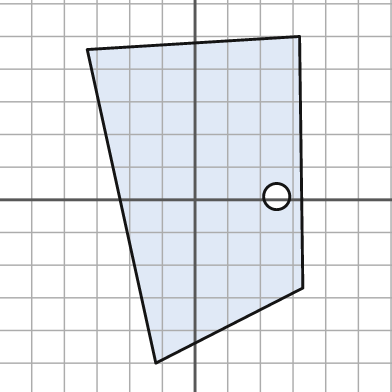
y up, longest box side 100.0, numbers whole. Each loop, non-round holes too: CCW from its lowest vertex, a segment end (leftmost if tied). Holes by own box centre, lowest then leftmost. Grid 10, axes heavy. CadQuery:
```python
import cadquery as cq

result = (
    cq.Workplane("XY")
    .moveTo(-12.0, -50.0)
    .lineTo(33.0, -27.0)
    .lineTo(32.0, 50.0)
    .lineTo(-33.0, 46.0)
    .close()
    .moveTo(25.0, 1.0)
    .circle(4.0)
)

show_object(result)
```